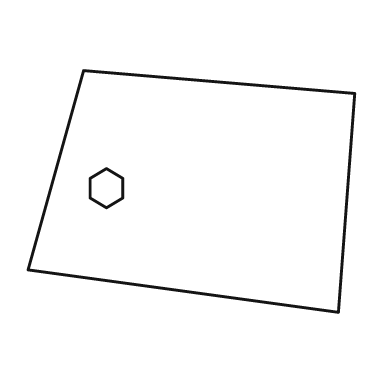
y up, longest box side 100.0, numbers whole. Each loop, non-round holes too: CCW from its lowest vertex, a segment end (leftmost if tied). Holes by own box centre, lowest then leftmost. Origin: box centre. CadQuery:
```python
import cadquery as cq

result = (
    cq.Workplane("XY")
    .moveTo(45.0, -37.0)
    .lineTo(50.0, 30.0)
    .lineTo(-33.0, 37.0)
    .lineTo(-50.0, -24.0)
    .close()
    .moveTo(-26.0, -5.0)
    .lineTo(-21.0, -2.0)
    .lineTo(-21.0, 4.0)
    .lineTo(-26.0, 7.0)
    .lineTo(-31.0, 4.0)
    .lineTo(-31.0, -2.0)
    .close()
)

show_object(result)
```